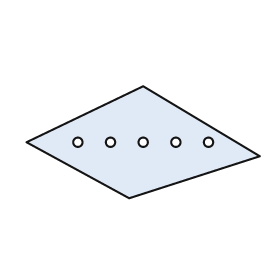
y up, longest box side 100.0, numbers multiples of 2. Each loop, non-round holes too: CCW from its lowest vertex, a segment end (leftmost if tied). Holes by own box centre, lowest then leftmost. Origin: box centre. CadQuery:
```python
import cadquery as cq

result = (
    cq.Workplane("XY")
    .moveTo(-6.0, -24.0)
    .lineTo(50.0, -6.0)
    .lineTo(0.0, 24.0)
    .lineTo(-50.0, 0.0)
    .close()
    .moveTo(-28.0, 0.0)
    .circle(2.0)
    .moveTo(-14.0, 0.0)
    .circle(2.0)
    .moveTo(0.0, 0.0)
    .circle(2.0)
    .moveTo(14.0, 0.0)
    .circle(2.0)
    .moveTo(28.0, 0.0)
    .circle(2.0)
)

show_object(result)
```